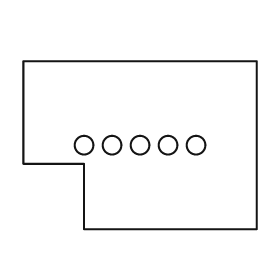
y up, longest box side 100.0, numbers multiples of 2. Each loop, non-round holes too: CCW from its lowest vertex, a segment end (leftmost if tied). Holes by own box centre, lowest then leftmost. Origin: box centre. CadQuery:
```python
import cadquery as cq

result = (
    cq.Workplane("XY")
    .moveTo(-24.0, -36.0)
    .lineTo(50.0, -36.0)
    .lineTo(50.0, 36.0)
    .lineTo(-50.0, 36.0)
    .lineTo(-50.0, -8.0)
    .lineTo(-24.0, -8.0)
    .close()
    .moveTo(-24.0, 0.0)
    .circle(4.0)
    .moveTo(-12.0, 0.0)
    .circle(4.0)
    .moveTo(0.0, 0.0)
    .circle(4.0)
    .moveTo(12.0, 0.0)
    .circle(4.0)
    .moveTo(24.0, 0.0)
    .circle(4.0)
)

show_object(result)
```